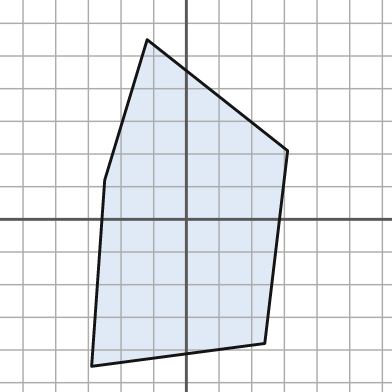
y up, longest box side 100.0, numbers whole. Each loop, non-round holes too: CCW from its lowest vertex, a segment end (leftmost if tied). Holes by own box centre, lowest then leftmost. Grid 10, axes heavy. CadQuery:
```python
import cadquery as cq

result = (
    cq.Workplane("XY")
    .moveTo(-29.0, -45.0)
    .lineTo(24.0, -38.0)
    .lineTo(31.0, 21.0)
    .lineTo(-12.0, 55.0)
    .lineTo(-25.0, 12.0)
    .close()
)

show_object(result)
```